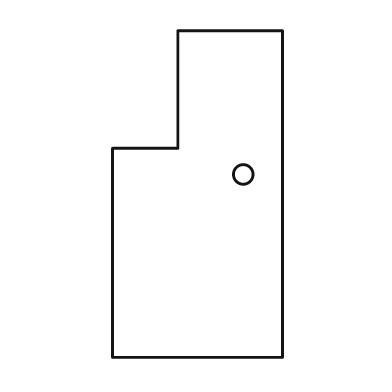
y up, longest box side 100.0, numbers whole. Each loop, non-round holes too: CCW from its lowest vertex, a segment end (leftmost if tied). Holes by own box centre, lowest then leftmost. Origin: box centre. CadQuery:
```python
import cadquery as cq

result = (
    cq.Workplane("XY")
    .moveTo(-26.0, -50.0)
    .lineTo(26.0, -50.0)
    .lineTo(26.0, 50.0)
    .lineTo(-6.0, 50.0)
    .lineTo(-6.0, 14.0)
    .lineTo(-26.0, 14.0)
    .close()
    .moveTo(14.0, 6.0)
    .circle(3.0)
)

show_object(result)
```